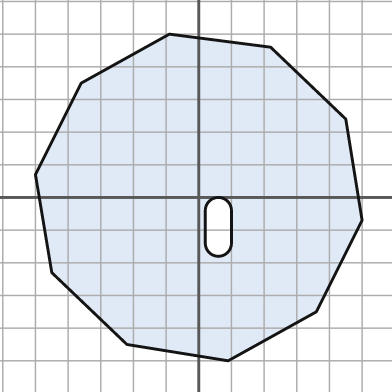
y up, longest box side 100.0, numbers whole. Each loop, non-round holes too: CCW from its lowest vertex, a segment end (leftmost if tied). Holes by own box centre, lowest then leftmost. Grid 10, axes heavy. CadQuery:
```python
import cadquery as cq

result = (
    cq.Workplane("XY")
    .moveTo(9.0, -50.0)
    .lineTo(36.0, -35.0)
    .lineTo(50.0, -7.0)
    .lineTo(45.0, 24.0)
    .lineTo(22.0, 46.0)
    .lineTo(-9.0, 50.0)
    .lineTo(-36.0, 35.0)
    .lineTo(-50.0, 7.0)
    .lineTo(-45.0, -23.0)
    .lineTo(-22.0, -45.0)
    .close()
    .moveTo(2.0, -14.0)
    .threePointArc((6.0, -18.0), (10.0, -14.0))
    .lineTo(10.0, -4.0)
    .threePointArc((6.0, 0.0), (2.0, -4.0))
    .close()
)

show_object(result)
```